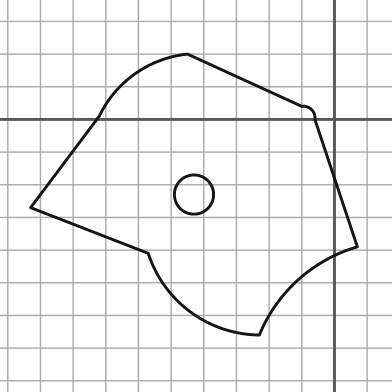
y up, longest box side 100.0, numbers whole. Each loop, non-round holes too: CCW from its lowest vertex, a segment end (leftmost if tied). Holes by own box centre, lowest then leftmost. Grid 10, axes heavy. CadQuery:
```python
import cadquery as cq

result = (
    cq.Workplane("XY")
    .moveTo(-23.0, -66.0)
    .threePointArc((-11.0, -49.0), (7.0, -39.0))
    .lineTo(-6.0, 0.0)
    .threePointArc((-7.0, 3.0), (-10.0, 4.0))
    .lineTo(-45.0, 20.0)
    .threePointArc((-61.0, 14.0), (-72.0, 1.0))
    .lineTo(-93.0, -27.0)
    .lineTo(-57.0, -41.0)
    .threePointArc((-44.0, -59.0), (-23.0, -66.0))
    .close()
    .moveTo(-43.0, -23.0)
    .circle(6.0)
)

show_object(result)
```